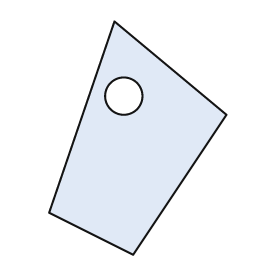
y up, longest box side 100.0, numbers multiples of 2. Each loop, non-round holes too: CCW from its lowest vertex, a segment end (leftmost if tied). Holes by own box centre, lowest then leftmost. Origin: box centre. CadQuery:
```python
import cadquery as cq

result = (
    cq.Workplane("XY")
    .moveTo(-2.0, -50.0)
    .lineTo(38.0, 10.0)
    .lineTo(-10.0, 50.0)
    .lineTo(-38.0, -32.0)
    .close()
    .moveTo(-6.0, 18.0)
    .circle(8.0)
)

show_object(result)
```